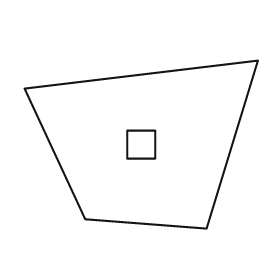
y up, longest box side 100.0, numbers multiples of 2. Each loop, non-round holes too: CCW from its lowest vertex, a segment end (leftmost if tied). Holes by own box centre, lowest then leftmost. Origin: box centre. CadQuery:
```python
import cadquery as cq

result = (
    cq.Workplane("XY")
    .moveTo(28.0, -36.0)
    .lineTo(50.0, 36.0)
    .lineTo(-50.0, 24.0)
    .lineTo(-24.0, -32.0)
    .close()
    .moveTo(-6.0, -6.0)
    .lineTo(6.0, -6.0)
    .lineTo(6.0, 6.0)
    .lineTo(-6.0, 6.0)
    .close()
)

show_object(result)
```